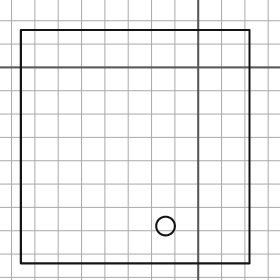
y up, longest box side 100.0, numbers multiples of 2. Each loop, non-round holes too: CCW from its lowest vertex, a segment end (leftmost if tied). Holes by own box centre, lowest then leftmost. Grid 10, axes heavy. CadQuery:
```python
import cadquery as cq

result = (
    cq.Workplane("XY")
    .moveTo(-76.0, -84.0)
    .lineTo(22.0, -84.0)
    .lineTo(22.0, 16.0)
    .lineTo(-76.0, 16.0)
    .close()
    .moveTo(-14.0, -68.0)
    .circle(4.0)
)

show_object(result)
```